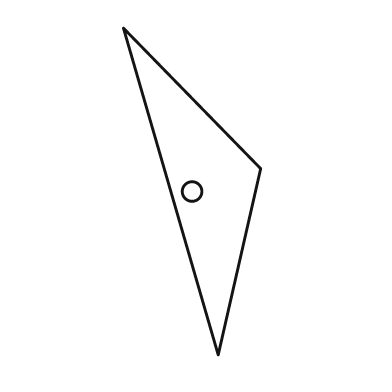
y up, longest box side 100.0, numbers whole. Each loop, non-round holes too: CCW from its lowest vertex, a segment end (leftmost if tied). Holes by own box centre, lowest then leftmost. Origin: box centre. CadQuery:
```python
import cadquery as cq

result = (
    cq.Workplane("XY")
    .moveTo(8.0, -50.0)
    .lineTo(21.0, 7.0)
    .lineTo(-21.0, 50.0)
    .close()
    .moveTo(0.0, 0.0)
    .circle(3.0)
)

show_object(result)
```